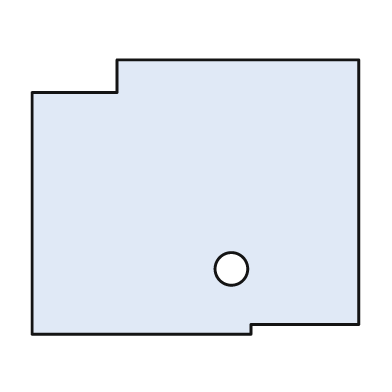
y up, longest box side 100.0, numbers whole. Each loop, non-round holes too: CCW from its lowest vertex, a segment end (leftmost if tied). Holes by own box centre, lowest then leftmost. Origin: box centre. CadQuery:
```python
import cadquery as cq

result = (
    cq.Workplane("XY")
    .moveTo(-50.0, -42.0)
    .lineTo(17.0, -42.0)
    .lineTo(17.0, -39.0)
    .lineTo(50.0, -39.0)
    .lineTo(50.0, 42.0)
    .lineTo(-24.0, 42.0)
    .lineTo(-24.0, 32.0)
    .lineTo(-50.0, 32.0)
    .close()
    .moveTo(11.0, -22.0)
    .circle(5.0)
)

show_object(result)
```